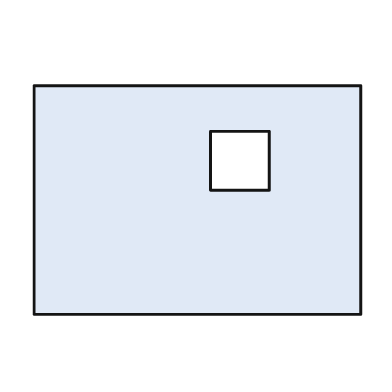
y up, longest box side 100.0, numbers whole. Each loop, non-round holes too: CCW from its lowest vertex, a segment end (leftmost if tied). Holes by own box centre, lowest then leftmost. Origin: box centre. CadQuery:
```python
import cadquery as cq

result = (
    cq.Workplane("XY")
    .moveTo(-50.0, -35.0)
    .lineTo(50.0, -35.0)
    .lineTo(50.0, 35.0)
    .lineTo(-50.0, 35.0)
    .close()
    .moveTo(4.0, 3.0)
    .lineTo(22.0, 3.0)
    .lineTo(22.0, 21.0)
    .lineTo(4.0, 21.0)
    .close()
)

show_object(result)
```